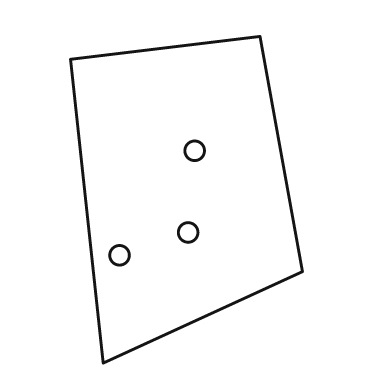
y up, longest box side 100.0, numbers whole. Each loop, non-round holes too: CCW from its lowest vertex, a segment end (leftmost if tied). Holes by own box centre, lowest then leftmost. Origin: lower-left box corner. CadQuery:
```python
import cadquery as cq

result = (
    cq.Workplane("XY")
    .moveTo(10.0, 0.0)
    .lineTo(71.0, 28.0)
    .lineTo(58.0, 100.0)
    .lineTo(0.0, 93.0)
    .close()
    .moveTo(15.0, 33.0)
    .circle(3.0)
    .moveTo(36.0, 40.0)
    .circle(3.0)
    .moveTo(38.0, 65.0)
    .circle(3.0)
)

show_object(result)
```